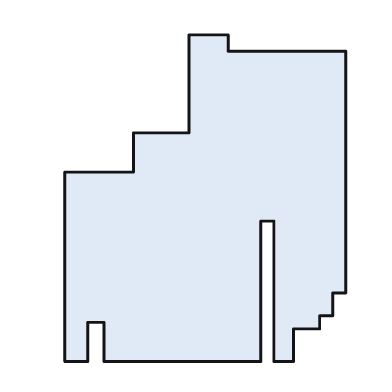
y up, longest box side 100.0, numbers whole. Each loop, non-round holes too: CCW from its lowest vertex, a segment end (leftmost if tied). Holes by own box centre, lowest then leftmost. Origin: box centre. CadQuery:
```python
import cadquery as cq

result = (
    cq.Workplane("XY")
    .moveTo(-43.0, -50.0)
    .lineTo(-36.0, -50.0)
    .lineTo(-36.0, -38.0)
    .lineTo(-31.0, -38.0)
    .lineTo(-31.0, -50.0)
    .lineTo(17.0, -50.0)
    .lineTo(17.0, -7.0)
    .lineTo(21.0, -7.0)
    .lineTo(21.0, -50.0)
    .lineTo(27.0, -50.0)
    .lineTo(27.0, -40.0)
    .lineTo(35.0, -40.0)
    .lineTo(35.0, -36.0)
    .lineTo(39.0, -36.0)
    .lineTo(39.0, -29.0)
    .lineTo(43.0, -29.0)
    .lineTo(43.0, 45.0)
    .lineTo(7.0, 45.0)
    .lineTo(7.0, 50.0)
    .lineTo(-5.0, 50.0)
    .lineTo(-5.0, 20.0)
    .lineTo(-22.0, 20.0)
    .lineTo(-22.0, 8.0)
    .lineTo(-43.0, 8.0)
    .close()
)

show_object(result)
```